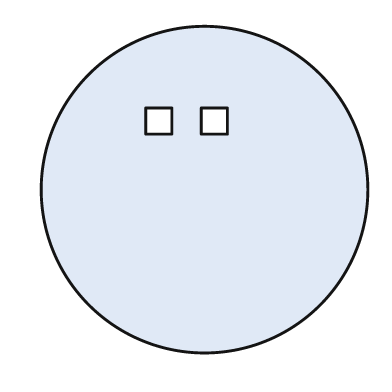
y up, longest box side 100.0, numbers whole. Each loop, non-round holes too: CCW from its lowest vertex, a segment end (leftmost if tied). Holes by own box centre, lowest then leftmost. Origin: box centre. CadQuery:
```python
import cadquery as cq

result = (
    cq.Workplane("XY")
    .moveTo(0.0, 0.0)
    .circle(50.0)
    .moveTo(-18.0, 17.0)
    .lineTo(-10.0, 17.0)
    .lineTo(-10.0, 25.0)
    .lineTo(-18.0, 25.0)
    .close()
    .moveTo(-1.0, 17.0)
    .lineTo(7.0, 17.0)
    .lineTo(7.0, 25.0)
    .lineTo(-1.0, 25.0)
    .close()
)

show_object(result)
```